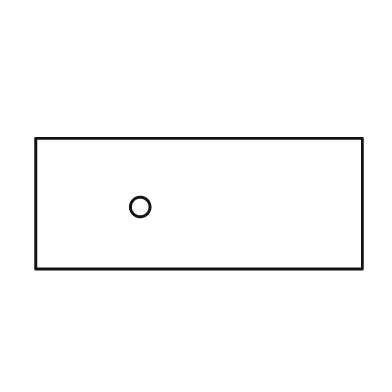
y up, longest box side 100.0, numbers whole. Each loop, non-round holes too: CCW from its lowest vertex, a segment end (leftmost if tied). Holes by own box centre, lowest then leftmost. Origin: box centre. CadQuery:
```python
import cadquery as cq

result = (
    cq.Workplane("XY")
    .moveTo(-50.0, -20.0)
    .lineTo(50.0, -20.0)
    .lineTo(50.0, 20.0)
    .lineTo(-50.0, 20.0)
    .close()
    .moveTo(-18.0, -1.0)
    .circle(3.0)
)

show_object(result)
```